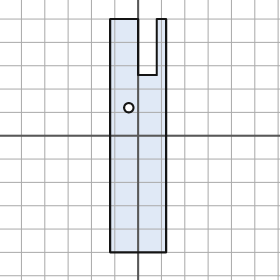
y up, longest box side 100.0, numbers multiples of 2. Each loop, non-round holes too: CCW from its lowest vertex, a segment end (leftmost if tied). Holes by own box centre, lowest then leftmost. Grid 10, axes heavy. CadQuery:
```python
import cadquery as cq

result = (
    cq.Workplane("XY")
    .moveTo(-12.0, -50.0)
    .lineTo(12.0, -50.0)
    .lineTo(12.0, 50.0)
    .lineTo(8.0, 50.0)
    .lineTo(8.0, 26.0)
    .lineTo(0.0, 26.0)
    .lineTo(0.0, 50.0)
    .lineTo(-12.0, 50.0)
    .close()
    .moveTo(-4.0, 12.0)
    .circle(2.0)
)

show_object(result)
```